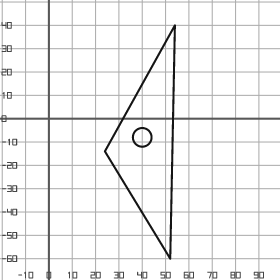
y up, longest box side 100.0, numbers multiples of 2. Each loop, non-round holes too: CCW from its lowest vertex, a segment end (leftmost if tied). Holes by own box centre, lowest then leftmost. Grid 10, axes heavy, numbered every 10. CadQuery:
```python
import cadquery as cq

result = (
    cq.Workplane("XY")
    .moveTo(52.0, -60.0)
    .lineTo(54.0, 40.0)
    .lineTo(24.0, -14.0)
    .close()
    .moveTo(40.0, -8.0)
    .circle(4.0)
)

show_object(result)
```